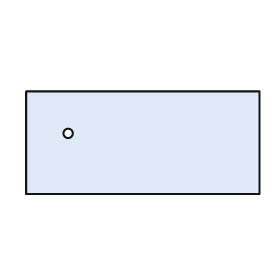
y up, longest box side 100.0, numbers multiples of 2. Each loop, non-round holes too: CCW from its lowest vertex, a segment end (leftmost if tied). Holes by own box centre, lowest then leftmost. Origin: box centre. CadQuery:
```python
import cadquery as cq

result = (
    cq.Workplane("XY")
    .moveTo(-50.0, -22.0)
    .lineTo(50.0, -22.0)
    .lineTo(50.0, 22.0)
    .lineTo(-50.0, 22.0)
    .close()
    .moveTo(-32.0, 4.0)
    .circle(2.0)
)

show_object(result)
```